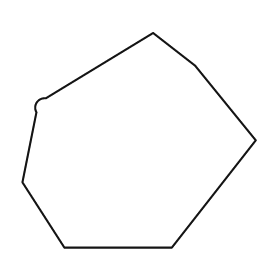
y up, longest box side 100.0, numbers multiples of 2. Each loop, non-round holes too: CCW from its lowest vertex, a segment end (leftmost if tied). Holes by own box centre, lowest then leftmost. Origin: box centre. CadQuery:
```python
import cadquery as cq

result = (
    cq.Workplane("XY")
    .moveTo(-32.0, -46.0)
    .lineTo(14.0, -46.0)
    .lineTo(50.0, 0.0)
    .lineTo(24.0, 32.0)
    .lineTo(6.0, 46.0)
    .lineTo(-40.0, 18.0)
    .threePointArc((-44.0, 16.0), (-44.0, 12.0))
    .lineTo(-50.0, -18.0)
    .close()
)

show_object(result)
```